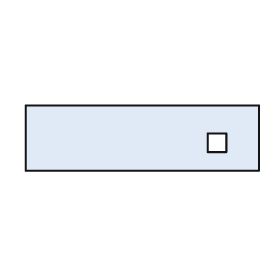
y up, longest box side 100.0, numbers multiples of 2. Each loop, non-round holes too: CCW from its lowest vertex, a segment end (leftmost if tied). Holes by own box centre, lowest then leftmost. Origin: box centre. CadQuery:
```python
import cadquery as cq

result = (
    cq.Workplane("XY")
    .moveTo(-50.0, -14.0)
    .lineTo(50.0, -14.0)
    .lineTo(50.0, 14.0)
    .lineTo(-50.0, 14.0)
    .close()
    .moveTo(28.0, -6.0)
    .lineTo(36.0, -6.0)
    .lineTo(36.0, 2.0)
    .lineTo(28.0, 2.0)
    .close()
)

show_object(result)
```